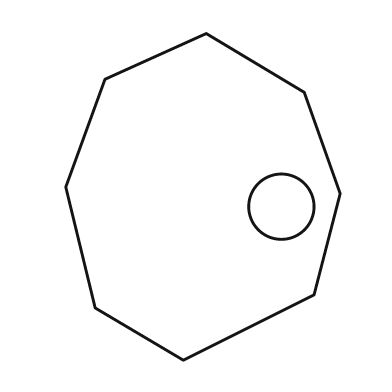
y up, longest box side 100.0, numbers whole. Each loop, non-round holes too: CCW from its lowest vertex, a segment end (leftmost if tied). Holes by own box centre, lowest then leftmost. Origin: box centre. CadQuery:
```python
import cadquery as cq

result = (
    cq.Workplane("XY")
    .moveTo(-6.0, -50.0)
    .lineTo(34.0, -30.0)
    .lineTo(42.0, 1.0)
    .lineTo(31.0, 32.0)
    .lineTo(1.0, 50.0)
    .lineTo(-30.0, 36.0)
    .lineTo(-42.0, 3.0)
    .lineTo(-33.0, -34.0)
    .close()
    .moveTo(24.0, -3.0)
    .circle(10.0)
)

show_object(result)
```